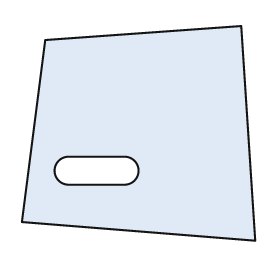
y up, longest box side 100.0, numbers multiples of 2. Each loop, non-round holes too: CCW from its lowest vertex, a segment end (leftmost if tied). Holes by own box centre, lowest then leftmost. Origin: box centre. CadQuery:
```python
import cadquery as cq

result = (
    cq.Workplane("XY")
    .moveTo(50.0, -46.0)
    .lineTo(44.0, 46.0)
    .lineTo(-40.0, 40.0)
    .lineTo(-50.0, -38.0)
    .close()
    .moveTo(-30.0, -22.0)
    .lineTo(-6.0, -22.0)
    .threePointArc((0.0, -16.0), (-6.0, -10.0))
    .lineTo(-30.0, -10.0)
    .threePointArc((-36.0, -16.0), (-30.0, -22.0))
    .close()
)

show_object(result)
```